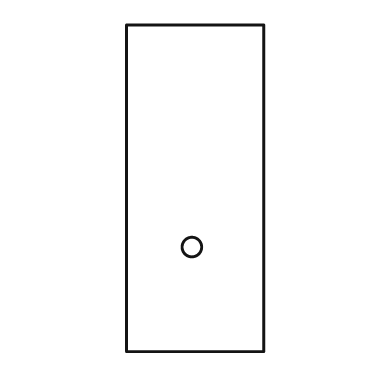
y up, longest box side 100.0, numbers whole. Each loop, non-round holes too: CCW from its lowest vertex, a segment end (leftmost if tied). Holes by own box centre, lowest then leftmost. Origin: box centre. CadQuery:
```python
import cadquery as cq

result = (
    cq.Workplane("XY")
    .moveTo(-21.0, -50.0)
    .lineTo(21.0, -50.0)
    .lineTo(21.0, 50.0)
    .lineTo(-21.0, 50.0)
    .close()
    .moveTo(-1.0, -18.0)
    .circle(3.0)
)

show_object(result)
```